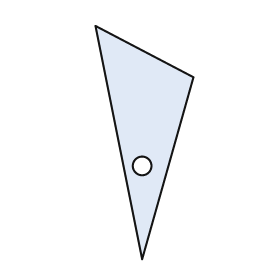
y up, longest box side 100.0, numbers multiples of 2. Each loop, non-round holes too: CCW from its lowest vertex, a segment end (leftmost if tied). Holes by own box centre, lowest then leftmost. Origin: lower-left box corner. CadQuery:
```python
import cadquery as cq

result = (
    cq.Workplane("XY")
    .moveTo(20.0, 0.0)
    .lineTo(42.0, 78.0)
    .lineTo(0.0, 100.0)
    .close()
    .moveTo(20.0, 40.0)
    .circle(4.0)
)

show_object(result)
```